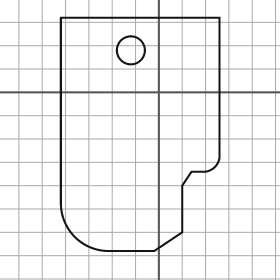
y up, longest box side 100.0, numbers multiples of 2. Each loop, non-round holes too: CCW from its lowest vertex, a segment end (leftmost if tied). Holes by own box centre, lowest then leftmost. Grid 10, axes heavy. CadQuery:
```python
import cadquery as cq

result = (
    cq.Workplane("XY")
    .moveTo(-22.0, -68.0)
    .lineTo(-2.0, -68.0)
    .lineTo(10.0, -60.0)
    .lineTo(10.0, -40.0)
    .lineTo(14.0, -34.0)
    .lineTo(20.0, -34.0)
    .threePointArc((24.0, -32.0), (26.0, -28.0))
    .lineTo(26.0, 32.0)
    .lineTo(-42.0, 32.0)
    .lineTo(-42.0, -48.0)
    .threePointArc((-36.0, -62.0), (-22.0, -68.0))
    .close()
    .moveTo(-12.0, 18.0)
    .circle(6.0)
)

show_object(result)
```